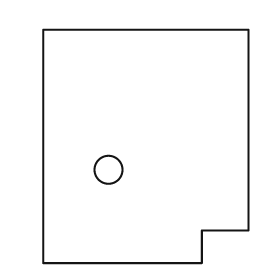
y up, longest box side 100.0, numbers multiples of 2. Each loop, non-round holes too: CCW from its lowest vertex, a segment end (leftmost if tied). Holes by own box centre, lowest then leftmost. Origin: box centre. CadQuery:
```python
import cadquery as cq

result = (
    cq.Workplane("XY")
    .moveTo(-44.0, -50.0)
    .lineTo(24.0, -50.0)
    .lineTo(24.0, -36.0)
    .lineTo(44.0, -36.0)
    .lineTo(44.0, 50.0)
    .lineTo(-44.0, 50.0)
    .close()
    .moveTo(-16.0, -10.0)
    .circle(6.0)
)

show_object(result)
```